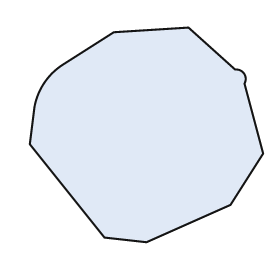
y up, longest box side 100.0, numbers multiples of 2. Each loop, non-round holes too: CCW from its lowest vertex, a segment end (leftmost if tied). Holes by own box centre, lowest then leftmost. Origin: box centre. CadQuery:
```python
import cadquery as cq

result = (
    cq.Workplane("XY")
    .moveTo(0.0, -46.0)
    .lineTo(36.0, -30.0)
    .lineTo(50.0, -8.0)
    .lineTo(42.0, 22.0)
    .threePointArc((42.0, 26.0), (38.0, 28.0))
    .lineTo(18.0, 46.0)
    .lineTo(-14.0, 44.0)
    .lineTo(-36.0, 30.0)
    .threePointArc((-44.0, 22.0), (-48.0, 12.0))
    .lineTo(-50.0, -4.0)
    .lineTo(-18.0, -44.0)
    .close()
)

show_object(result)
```